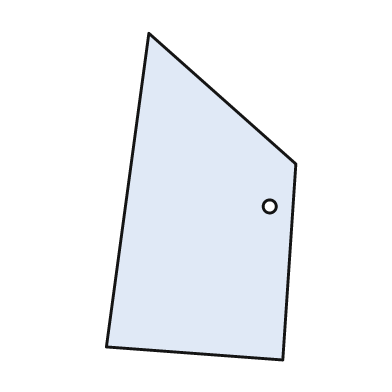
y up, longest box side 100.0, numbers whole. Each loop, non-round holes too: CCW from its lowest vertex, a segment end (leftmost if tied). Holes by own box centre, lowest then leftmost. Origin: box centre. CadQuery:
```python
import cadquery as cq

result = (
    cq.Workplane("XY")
    .moveTo(25.0, -50.0)
    .lineTo(29.0, 10.0)
    .lineTo(-16.0, 50.0)
    .lineTo(-29.0, -46.0)
    .close()
    .moveTo(21.0, -3.0)
    .circle(2.0)
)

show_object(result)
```